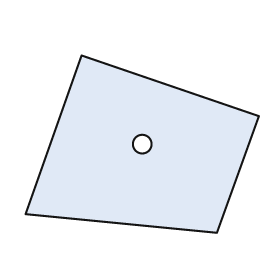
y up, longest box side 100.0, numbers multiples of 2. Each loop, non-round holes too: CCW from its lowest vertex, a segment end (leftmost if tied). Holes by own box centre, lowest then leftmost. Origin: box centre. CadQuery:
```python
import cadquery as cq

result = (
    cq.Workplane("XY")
    .moveTo(32.0, -38.0)
    .lineTo(50.0, 12.0)
    .lineTo(-26.0, 38.0)
    .lineTo(-50.0, -30.0)
    .close()
    .moveTo(0.0, 0.0)
    .circle(4.0)
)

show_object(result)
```